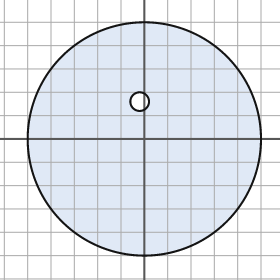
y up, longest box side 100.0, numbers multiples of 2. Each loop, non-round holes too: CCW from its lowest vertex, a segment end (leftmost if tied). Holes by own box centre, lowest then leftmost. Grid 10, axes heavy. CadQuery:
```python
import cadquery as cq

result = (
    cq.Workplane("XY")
    .moveTo(0.0, 0.0)
    .circle(50.0)
    .moveTo(-2.0, 16.0)
    .circle(4.0)
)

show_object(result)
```